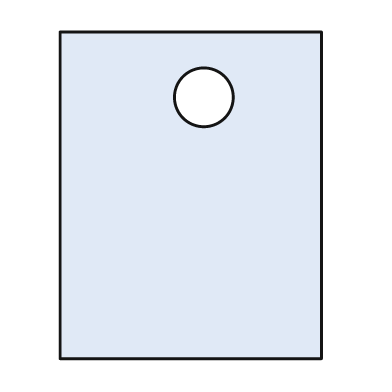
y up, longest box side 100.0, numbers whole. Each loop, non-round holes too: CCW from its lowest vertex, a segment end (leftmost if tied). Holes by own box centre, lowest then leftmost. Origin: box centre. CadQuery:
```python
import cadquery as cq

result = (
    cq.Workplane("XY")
    .moveTo(-40.0, -50.0)
    .lineTo(40.0, -50.0)
    .lineTo(40.0, 50.0)
    .lineTo(-40.0, 50.0)
    .close()
    .moveTo(4.0, 30.0)
    .circle(9.0)
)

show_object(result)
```